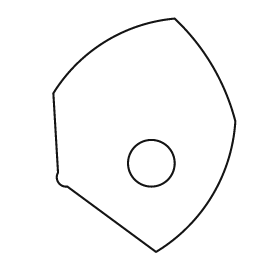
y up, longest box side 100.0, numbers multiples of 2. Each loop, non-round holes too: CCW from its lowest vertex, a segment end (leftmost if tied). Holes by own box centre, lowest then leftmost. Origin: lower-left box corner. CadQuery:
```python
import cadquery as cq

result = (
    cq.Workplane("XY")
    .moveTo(44.0, 0.0)
    .threePointArc((68.0, 24.0), (78.0, 56.0))
    .threePointArc((68.0, 80.0), (52.0, 100.0))
    .threePointArc((22.0, 90.0), (0.0, 68.0))
    .lineTo(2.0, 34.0)
    .threePointArc((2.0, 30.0), (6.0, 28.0))
    .close()
    .moveTo(42.0, 38.0)
    .circle(10.0)
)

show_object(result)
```